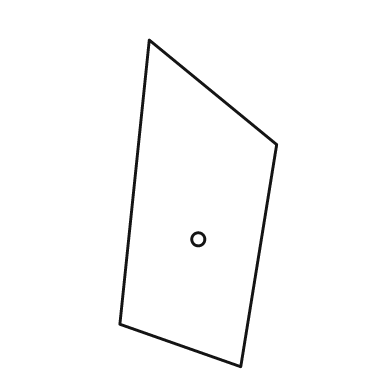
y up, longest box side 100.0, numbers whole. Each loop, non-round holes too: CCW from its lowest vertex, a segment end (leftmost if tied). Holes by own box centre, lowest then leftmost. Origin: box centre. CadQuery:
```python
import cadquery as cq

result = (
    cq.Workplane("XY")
    .moveTo(13.0, -50.0)
    .lineTo(24.0, 18.0)
    .lineTo(-15.0, 50.0)
    .lineTo(-24.0, -37.0)
    .close()
    .moveTo(0.0, -11.0)
    .circle(2.0)
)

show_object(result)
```